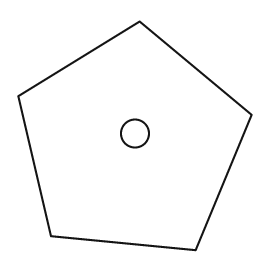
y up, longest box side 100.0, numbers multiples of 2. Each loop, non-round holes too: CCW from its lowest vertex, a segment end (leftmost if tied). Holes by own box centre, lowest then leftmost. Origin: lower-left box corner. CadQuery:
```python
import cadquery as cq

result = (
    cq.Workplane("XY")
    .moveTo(76.0, 0.0)
    .lineTo(100.0, 58.0)
    .lineTo(52.0, 98.0)
    .lineTo(0.0, 66.0)
    .lineTo(14.0, 6.0)
    .close()
    .moveTo(50.0, 50.0)
    .circle(6.0)
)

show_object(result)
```